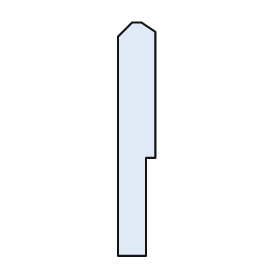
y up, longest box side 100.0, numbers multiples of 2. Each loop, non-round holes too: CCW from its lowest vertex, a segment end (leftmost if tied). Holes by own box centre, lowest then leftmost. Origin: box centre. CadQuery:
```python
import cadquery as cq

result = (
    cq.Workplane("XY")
    .moveTo(-8.0, -50.0)
    .lineTo(4.0, -50.0)
    .lineTo(4.0, -8.0)
    .lineTo(8.0, -8.0)
    .lineTo(8.0, 46.0)
    .lineTo(2.0, 50.0)
    .lineTo(-2.0, 50.0)
    .lineTo(-8.0, 44.0)
    .close()
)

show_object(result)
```